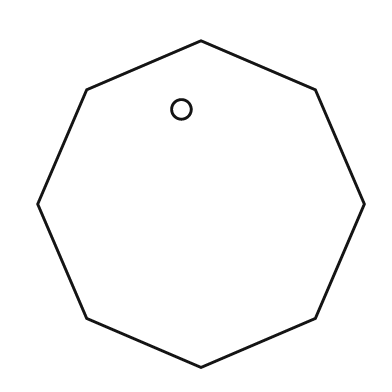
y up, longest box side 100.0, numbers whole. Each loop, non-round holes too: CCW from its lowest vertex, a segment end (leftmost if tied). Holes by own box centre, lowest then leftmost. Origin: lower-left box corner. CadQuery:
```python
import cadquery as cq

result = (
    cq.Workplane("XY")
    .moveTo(50.0, 0.0)
    .lineTo(85.0, 15.0)
    .lineTo(100.0, 50.0)
    .lineTo(85.0, 85.0)
    .lineTo(50.0, 100.0)
    .lineTo(15.0, 85.0)
    .lineTo(0.0, 50.0)
    .lineTo(15.0, 15.0)
    .close()
    .moveTo(44.0, 79.0)
    .circle(3.0)
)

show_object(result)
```